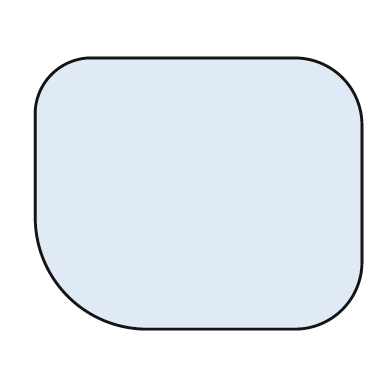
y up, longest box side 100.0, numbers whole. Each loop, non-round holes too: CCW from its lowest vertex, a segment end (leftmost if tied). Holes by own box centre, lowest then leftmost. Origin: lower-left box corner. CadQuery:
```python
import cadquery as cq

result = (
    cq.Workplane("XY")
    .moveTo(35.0, 0.0)
    .lineTo(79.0, 0.0)
    .threePointArc((94.0, 6.0), (100.0, 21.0))
    .lineTo(100.0, 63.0)
    .threePointArc((94.0, 77.0), (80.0, 83.0))
    .lineTo(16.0, 83.0)
    .threePointArc((5.0, 78.0), (0.0, 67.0))
    .lineTo(0.0, 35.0)
    .threePointArc((10.0, 10.0), (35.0, 0.0))
    .close()
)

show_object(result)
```